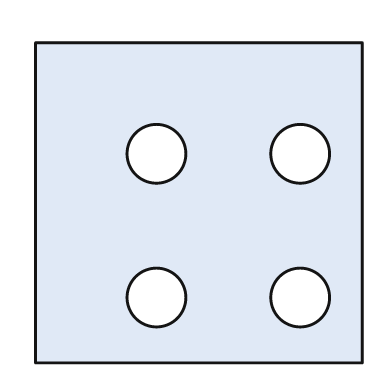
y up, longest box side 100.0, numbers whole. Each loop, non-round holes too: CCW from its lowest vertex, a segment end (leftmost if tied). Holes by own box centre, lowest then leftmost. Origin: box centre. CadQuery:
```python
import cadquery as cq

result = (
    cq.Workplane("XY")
    .moveTo(-50.0, -49.0)
    .lineTo(50.0, -49.0)
    .lineTo(50.0, 49.0)
    .lineTo(-50.0, 49.0)
    .close()
    .moveTo(-13.0, -29.0)
    .circle(9.0)
    .moveTo(31.0, -29.0)
    .circle(9.0)
    .moveTo(-13.0, 15.0)
    .circle(9.0)
    .moveTo(31.0, 15.0)
    .circle(9.0)
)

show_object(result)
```